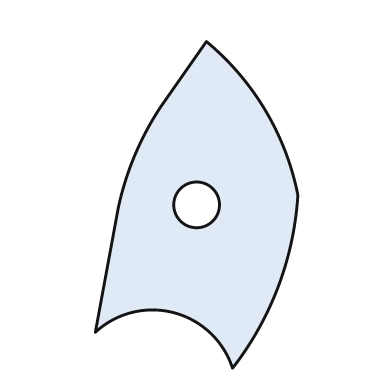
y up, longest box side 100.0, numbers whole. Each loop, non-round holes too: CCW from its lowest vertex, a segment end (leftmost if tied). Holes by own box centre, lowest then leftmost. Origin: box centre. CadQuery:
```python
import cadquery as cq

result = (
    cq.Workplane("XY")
    .moveTo(11.0, -50.0)
    .threePointArc((25.0, -25.0), (31.0, 3.0))
    .threePointArc((21.0, 29.0), (3.0, 50.0))
    .lineTo(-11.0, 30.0)
    .threePointArc((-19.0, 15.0), (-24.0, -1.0))
    .lineTo(-31.0, -39.0)
    .threePointArc((-7.0, -33.0), (11.0, -50.0))
    .close()
    .moveTo(0.0, 0.0)
    .circle(7.0)
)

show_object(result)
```